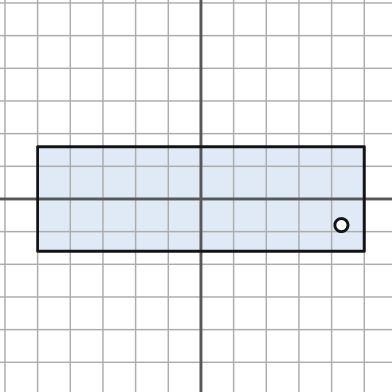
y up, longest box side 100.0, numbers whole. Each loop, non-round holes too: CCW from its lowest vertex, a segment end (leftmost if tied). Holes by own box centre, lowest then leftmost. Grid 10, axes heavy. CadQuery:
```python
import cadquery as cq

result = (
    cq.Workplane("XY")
    .moveTo(-50.0, -16.0)
    .lineTo(50.0, -16.0)
    .lineTo(50.0, 16.0)
    .lineTo(-50.0, 16.0)
    .close()
    .moveTo(43.0, -8.0)
    .circle(2.0)
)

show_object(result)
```